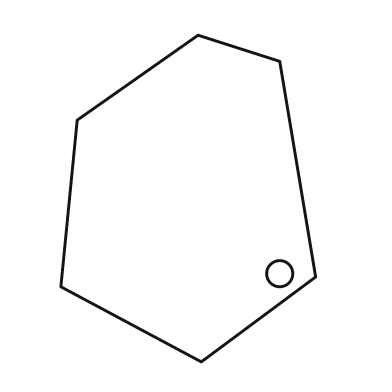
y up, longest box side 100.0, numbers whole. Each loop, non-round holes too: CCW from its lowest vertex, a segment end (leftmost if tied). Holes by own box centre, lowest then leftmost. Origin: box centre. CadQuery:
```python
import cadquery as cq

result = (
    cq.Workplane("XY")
    .moveTo(4.0, -50.0)
    .lineTo(39.0, -24.0)
    .lineTo(28.0, 42.0)
    .lineTo(3.0, 50.0)
    .lineTo(-34.0, 24.0)
    .lineTo(-39.0, -27.0)
    .close()
    .moveTo(28.0, -23.0)
    .circle(4.0)
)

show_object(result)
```